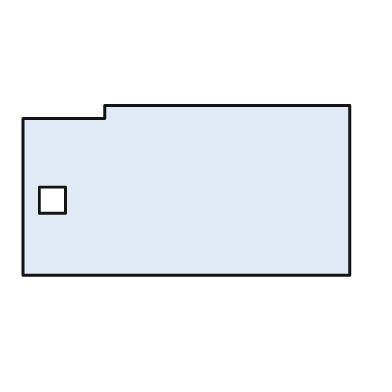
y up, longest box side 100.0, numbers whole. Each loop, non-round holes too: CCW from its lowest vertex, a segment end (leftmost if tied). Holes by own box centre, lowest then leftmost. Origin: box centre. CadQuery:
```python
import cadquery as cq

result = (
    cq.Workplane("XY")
    .moveTo(-50.0, -26.0)
    .lineTo(50.0, -26.0)
    .lineTo(50.0, 26.0)
    .lineTo(-25.0, 26.0)
    .lineTo(-25.0, 22.0)
    .lineTo(-50.0, 22.0)
    .close()
    .moveTo(-45.0, -7.0)
    .lineTo(-37.0, -7.0)
    .lineTo(-37.0, 1.0)
    .lineTo(-45.0, 1.0)
    .close()
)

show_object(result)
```